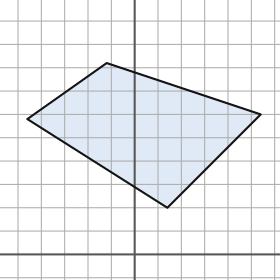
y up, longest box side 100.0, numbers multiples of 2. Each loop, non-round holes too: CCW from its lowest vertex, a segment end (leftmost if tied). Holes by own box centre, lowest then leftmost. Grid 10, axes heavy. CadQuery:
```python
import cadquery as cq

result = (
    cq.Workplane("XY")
    .moveTo(14.0, 20.0)
    .lineTo(54.0, 60.0)
    .lineTo(-12.0, 82.0)
    .lineTo(-46.0, 58.0)
    .close()
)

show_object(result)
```